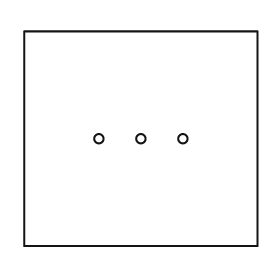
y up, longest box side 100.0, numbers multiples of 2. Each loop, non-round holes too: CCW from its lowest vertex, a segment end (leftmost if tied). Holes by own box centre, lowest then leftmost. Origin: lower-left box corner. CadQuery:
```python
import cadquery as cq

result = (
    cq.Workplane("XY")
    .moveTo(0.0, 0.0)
    .lineTo(100.0, 0.0)
    .lineTo(100.0, 92.0)
    .lineTo(0.0, 92.0)
    .close()
    .moveTo(32.0, 46.0)
    .circle(2.0)
    .moveTo(50.0, 46.0)
    .circle(2.0)
    .moveTo(68.0, 46.0)
    .circle(2.0)
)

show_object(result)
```